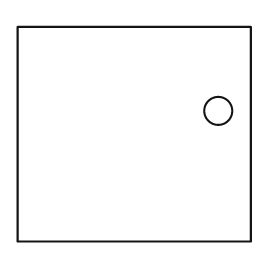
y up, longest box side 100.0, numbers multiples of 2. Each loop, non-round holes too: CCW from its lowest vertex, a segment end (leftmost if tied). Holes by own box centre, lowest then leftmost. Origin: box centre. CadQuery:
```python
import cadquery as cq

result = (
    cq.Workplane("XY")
    .moveTo(-50.0, -46.0)
    .lineTo(50.0, -46.0)
    .lineTo(50.0, 46.0)
    .lineTo(-50.0, 46.0)
    .close()
    .moveTo(36.0, 10.0)
    .circle(6.0)
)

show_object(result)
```